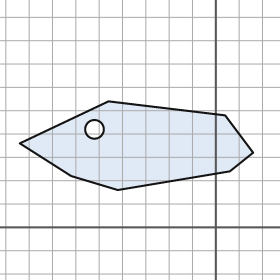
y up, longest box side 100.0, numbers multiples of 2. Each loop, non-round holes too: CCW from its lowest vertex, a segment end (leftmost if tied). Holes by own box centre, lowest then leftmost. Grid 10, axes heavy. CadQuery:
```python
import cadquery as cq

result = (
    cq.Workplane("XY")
    .moveTo(-42.0, 16.0)
    .lineTo(6.0, 24.0)
    .lineTo(16.0, 32.0)
    .lineTo(4.0, 48.0)
    .lineTo(-46.0, 54.0)
    .lineTo(-84.0, 36.0)
    .lineTo(-62.0, 22.0)
    .close()
    .moveTo(-52.0, 42.0)
    .circle(4.0)
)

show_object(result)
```